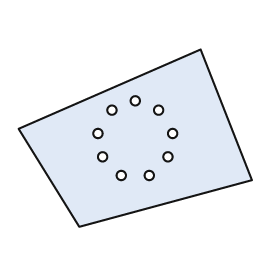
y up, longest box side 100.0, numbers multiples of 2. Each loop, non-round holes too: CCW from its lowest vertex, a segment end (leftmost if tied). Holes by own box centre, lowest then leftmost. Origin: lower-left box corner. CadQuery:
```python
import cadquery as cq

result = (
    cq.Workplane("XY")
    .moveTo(26.0, 0.0)
    .lineTo(100.0, 20.0)
    .lineTo(78.0, 76.0)
    .lineTo(0.0, 42.0)
    .close()
    .moveTo(44.0, 22.0)
    .circle(2.0)
    .moveTo(56.0, 22.0)
    .circle(2.0)
    .moveTo(36.0, 30.0)
    .circle(2.0)
    .moveTo(64.0, 30.0)
    .circle(2.0)
    .moveTo(34.0, 40.0)
    .circle(2.0)
    .moveTo(66.0, 40.0)
    .circle(2.0)
    .moveTo(40.0, 50.0)
    .circle(2.0)
    .moveTo(60.0, 50.0)
    .circle(2.0)
    .moveTo(50.0, 54.0)
    .circle(2.0)
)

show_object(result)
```